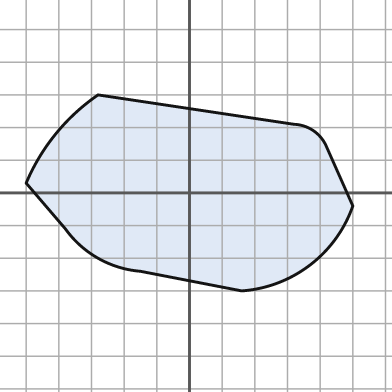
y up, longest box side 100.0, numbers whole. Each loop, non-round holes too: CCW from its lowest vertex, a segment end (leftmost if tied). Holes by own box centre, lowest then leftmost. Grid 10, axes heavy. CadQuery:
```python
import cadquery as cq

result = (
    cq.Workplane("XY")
    .moveTo(16.0, -30.0)
    .threePointArc((37.0, -22.0), (50.0, -4.0))
    .lineTo(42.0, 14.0)
    .threePointArc((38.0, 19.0), (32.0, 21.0))
    .lineTo(-28.0, 30.0)
    .threePointArc((-41.0, 18.0), (-50.0, 3.0))
    .lineTo(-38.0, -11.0)
    .threePointArc((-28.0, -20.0), (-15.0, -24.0))
    .close()
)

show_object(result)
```